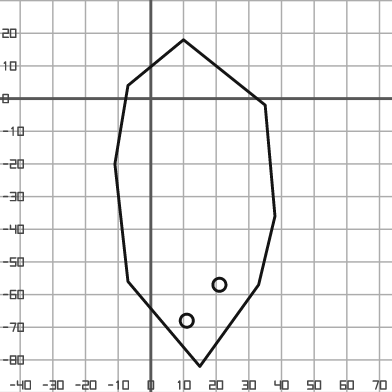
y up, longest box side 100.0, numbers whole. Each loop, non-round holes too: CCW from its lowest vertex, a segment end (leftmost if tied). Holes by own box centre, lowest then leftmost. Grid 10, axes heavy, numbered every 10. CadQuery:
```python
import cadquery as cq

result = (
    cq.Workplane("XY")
    .moveTo(15.0, -82.0)
    .lineTo(33.0, -57.0)
    .lineTo(38.0, -36.0)
    .lineTo(35.0, -2.0)
    .lineTo(10.0, 18.0)
    .lineTo(-7.0, 4.0)
    .lineTo(-11.0, -20.0)
    .lineTo(-7.0, -56.0)
    .close()
    .moveTo(11.0, -68.0)
    .circle(2.0)
    .moveTo(21.0, -57.0)
    .circle(2.0)
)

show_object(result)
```